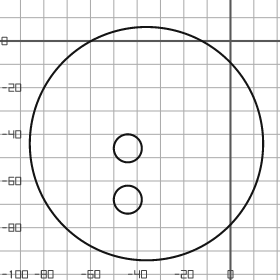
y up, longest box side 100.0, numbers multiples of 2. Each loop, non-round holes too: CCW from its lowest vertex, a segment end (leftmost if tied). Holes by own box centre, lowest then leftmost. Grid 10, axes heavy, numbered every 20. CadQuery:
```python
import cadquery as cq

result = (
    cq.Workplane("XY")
    .moveTo(-36.0, -44.0)
    .circle(50.0)
    .moveTo(-44.0, -68.0)
    .circle(6.0)
    .moveTo(-44.0, -46.0)
    .circle(6.0)
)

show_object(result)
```